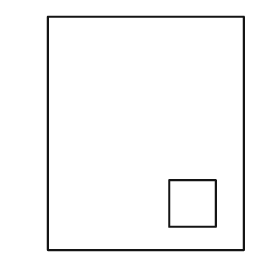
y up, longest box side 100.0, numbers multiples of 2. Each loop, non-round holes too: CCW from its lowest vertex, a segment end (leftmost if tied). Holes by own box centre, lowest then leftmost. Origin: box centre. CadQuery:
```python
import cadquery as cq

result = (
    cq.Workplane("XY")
    .moveTo(-42.0, -50.0)
    .lineTo(42.0, -50.0)
    .lineTo(42.0, 50.0)
    .lineTo(-42.0, 50.0)
    .close()
    .moveTo(10.0, -40.0)
    .lineTo(30.0, -40.0)
    .lineTo(30.0, -20.0)
    .lineTo(10.0, -20.0)
    .close()
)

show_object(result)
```